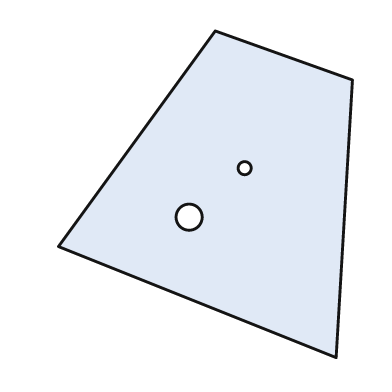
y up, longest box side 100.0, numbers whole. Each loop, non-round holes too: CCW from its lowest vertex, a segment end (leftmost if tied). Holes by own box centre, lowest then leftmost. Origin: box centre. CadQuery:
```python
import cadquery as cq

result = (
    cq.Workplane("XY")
    .moveTo(40.0, -50.0)
    .lineTo(45.0, 35.0)
    .lineTo(3.0, 50.0)
    .lineTo(-45.0, -16.0)
    .close()
    .moveTo(-5.0, -7.0)
    .circle(4.0)
    .moveTo(12.0, 8.0)
    .circle(2.0)
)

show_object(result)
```